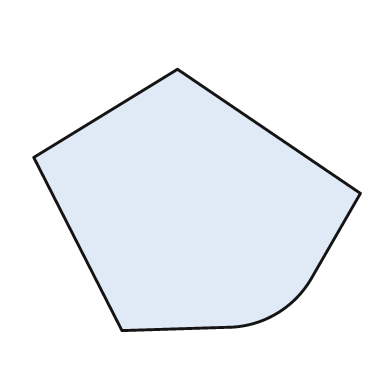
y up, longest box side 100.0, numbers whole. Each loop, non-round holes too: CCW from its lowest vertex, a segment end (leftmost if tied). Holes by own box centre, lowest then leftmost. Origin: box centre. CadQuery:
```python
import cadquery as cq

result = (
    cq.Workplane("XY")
    .moveTo(-23.0, -40.0)
    .lineTo(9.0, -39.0)
    .threePointArc((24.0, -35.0), (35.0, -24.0))
    .lineTo(50.0, 2.0)
    .lineTo(-6.0, 40.0)
    .lineTo(-50.0, 13.0)
    .close()
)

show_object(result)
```